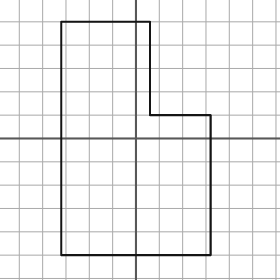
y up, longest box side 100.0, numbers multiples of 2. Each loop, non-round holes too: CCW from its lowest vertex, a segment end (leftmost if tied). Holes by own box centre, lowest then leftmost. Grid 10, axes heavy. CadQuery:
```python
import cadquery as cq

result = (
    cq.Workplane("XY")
    .moveTo(-32.0, -50.0)
    .lineTo(32.0, -50.0)
    .lineTo(32.0, 10.0)
    .lineTo(6.0, 10.0)
    .lineTo(6.0, 50.0)
    .lineTo(-32.0, 50.0)
    .close()
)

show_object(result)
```